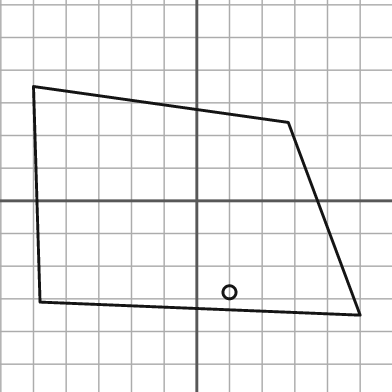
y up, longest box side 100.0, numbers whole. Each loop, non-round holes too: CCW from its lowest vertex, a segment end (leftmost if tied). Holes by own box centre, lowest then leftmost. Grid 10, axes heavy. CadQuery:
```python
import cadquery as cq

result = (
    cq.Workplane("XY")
    .moveTo(50.0, -35.0)
    .lineTo(28.0, 24.0)
    .lineTo(-50.0, 35.0)
    .lineTo(-48.0, -31.0)
    .close()
    .moveTo(10.0, -28.0)
    .circle(2.0)
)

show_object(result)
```